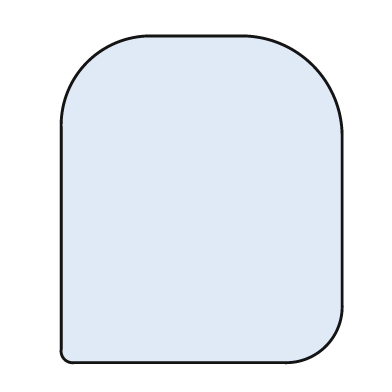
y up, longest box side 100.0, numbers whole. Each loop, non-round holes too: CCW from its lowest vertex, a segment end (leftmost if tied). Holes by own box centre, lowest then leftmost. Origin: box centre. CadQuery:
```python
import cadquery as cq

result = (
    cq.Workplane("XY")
    .moveTo(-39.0, -50.0)
    .lineTo(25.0, -50.0)
    .threePointArc((38.0, -45.0), (43.0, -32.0))
    .lineTo(43.0, 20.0)
    .threePointArc((34.0, 41.0), (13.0, 50.0))
    .lineTo(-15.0, 50.0)
    .threePointArc((-35.0, 42.0), (-43.0, 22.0))
    .lineTo(-43.0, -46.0)
    .threePointArc((-42.0, -49.0), (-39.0, -50.0))
    .close()
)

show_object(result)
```